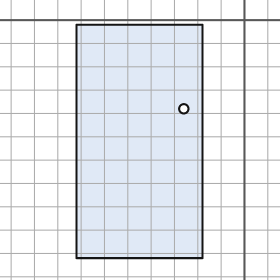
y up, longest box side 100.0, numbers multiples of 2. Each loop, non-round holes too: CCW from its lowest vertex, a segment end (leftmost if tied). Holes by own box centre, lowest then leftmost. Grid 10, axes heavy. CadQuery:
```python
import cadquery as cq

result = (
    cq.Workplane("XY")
    .moveTo(-72.0, -102.0)
    .lineTo(-18.0, -102.0)
    .lineTo(-18.0, -2.0)
    .lineTo(-72.0, -2.0)
    .close()
    .moveTo(-26.0, -38.0)
    .circle(2.0)
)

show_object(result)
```